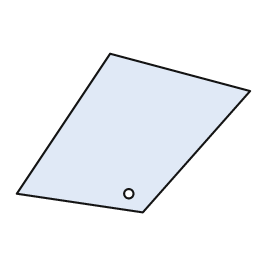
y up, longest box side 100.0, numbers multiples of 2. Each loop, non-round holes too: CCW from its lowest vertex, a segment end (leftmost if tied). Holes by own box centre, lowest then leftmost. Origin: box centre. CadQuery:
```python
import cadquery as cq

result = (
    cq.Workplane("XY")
    .moveTo(4.0, -34.0)
    .lineTo(50.0, 18.0)
    .lineTo(-10.0, 34.0)
    .lineTo(-50.0, -26.0)
    .close()
    .moveTo(-2.0, -26.0)
    .circle(2.0)
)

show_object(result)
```